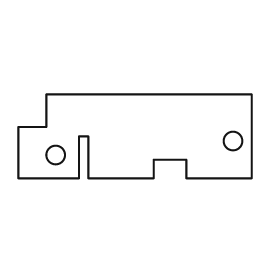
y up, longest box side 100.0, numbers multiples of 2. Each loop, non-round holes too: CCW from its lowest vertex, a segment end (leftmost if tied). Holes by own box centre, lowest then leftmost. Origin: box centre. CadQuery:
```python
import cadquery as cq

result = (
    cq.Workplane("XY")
    .moveTo(-50.0, -18.0)
    .lineTo(-24.0, -18.0)
    .lineTo(-24.0, 0.0)
    .lineTo(-20.0, 0.0)
    .lineTo(-20.0, -18.0)
    .lineTo(8.0, -18.0)
    .lineTo(8.0, -10.0)
    .lineTo(22.0, -10.0)
    .lineTo(22.0, -18.0)
    .lineTo(50.0, -18.0)
    .lineTo(50.0, 18.0)
    .lineTo(-38.0, 18.0)
    .lineTo(-38.0, 4.0)
    .lineTo(-50.0, 4.0)
    .close()
    .moveTo(-34.0, -8.0)
    .circle(4.0)
    .moveTo(42.0, -2.0)
    .circle(4.0)
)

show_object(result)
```